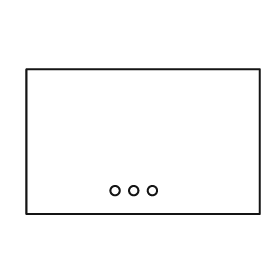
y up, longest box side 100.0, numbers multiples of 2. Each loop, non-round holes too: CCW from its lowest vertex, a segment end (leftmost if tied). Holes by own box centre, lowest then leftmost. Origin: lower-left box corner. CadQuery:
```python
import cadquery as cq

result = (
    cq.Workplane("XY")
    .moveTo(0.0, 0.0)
    .lineTo(100.0, 0.0)
    .lineTo(100.0, 62.0)
    .lineTo(0.0, 62.0)
    .close()
    .moveTo(38.0, 10.0)
    .circle(2.0)
    .moveTo(46.0, 10.0)
    .circle(2.0)
    .moveTo(54.0, 10.0)
    .circle(2.0)
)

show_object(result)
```